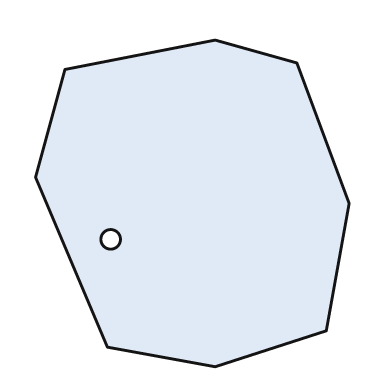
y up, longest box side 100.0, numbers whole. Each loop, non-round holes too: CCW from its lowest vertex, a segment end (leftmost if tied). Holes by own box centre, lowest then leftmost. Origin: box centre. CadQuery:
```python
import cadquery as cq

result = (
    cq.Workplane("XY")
    .moveTo(7.0, -50.0)
    .lineTo(41.0, -39.0)
    .lineTo(48.0, 0.0)
    .lineTo(32.0, 43.0)
    .lineTo(7.0, 50.0)
    .lineTo(-39.0, 41.0)
    .lineTo(-48.0, 8.0)
    .lineTo(-26.0, -44.0)
    .close()
    .moveTo(-25.0, -11.0)
    .circle(3.0)
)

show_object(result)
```